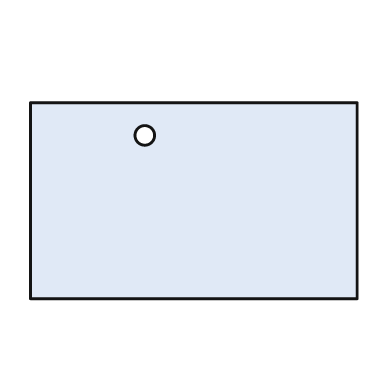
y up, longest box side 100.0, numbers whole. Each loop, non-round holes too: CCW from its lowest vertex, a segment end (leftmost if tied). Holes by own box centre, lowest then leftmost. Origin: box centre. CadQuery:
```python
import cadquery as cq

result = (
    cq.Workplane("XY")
    .moveTo(-50.0, -30.0)
    .lineTo(50.0, -30.0)
    .lineTo(50.0, 30.0)
    .lineTo(-50.0, 30.0)
    .close()
    .moveTo(-15.0, 20.0)
    .circle(3.0)
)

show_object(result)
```